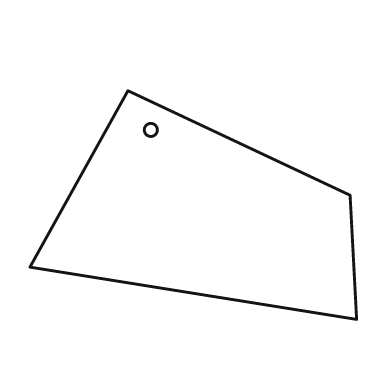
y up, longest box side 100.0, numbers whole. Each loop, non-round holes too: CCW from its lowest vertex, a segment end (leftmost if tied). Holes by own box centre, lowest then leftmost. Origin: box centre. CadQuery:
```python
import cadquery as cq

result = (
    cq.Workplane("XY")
    .moveTo(50.0, -35.0)
    .lineTo(48.0, 3.0)
    .lineTo(-20.0, 35.0)
    .lineTo(-50.0, -19.0)
    .close()
    .moveTo(-13.0, 23.0)
    .circle(2.0)
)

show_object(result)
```